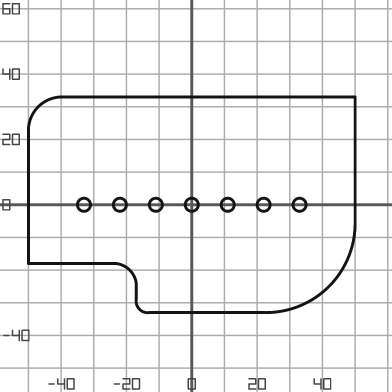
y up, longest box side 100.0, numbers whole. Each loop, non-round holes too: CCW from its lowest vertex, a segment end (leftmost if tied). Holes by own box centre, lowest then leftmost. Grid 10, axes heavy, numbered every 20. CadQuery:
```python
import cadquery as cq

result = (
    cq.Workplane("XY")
    .moveTo(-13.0, -33.0)
    .lineTo(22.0, -33.0)
    .threePointArc((42.0, -25.0), (50.0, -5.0))
    .lineTo(50.0, 33.0)
    .lineTo(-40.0, 33.0)
    .threePointArc((-47.0, 30.0), (-50.0, 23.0))
    .lineTo(-50.0, -18.0)
    .lineTo(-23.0, -18.0)
    .threePointArc((-19.0, -20.0), (-17.0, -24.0))
    .lineTo(-17.0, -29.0)
    .threePointArc((-16.0, -32.0), (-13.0, -33.0))
    .close()
    .moveTo(-33.0, 0.0)
    .circle(2.0)
    .moveTo(-22.0, 0.0)
    .circle(2.0)
    .moveTo(-11.0, 0.0)
    .circle(2.0)
    .moveTo(0.0, 0.0)
    .circle(2.0)
    .moveTo(11.0, 0.0)
    .circle(2.0)
    .moveTo(22.0, 0.0)
    .circle(2.0)
    .moveTo(33.0, 0.0)
    .circle(2.0)
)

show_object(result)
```